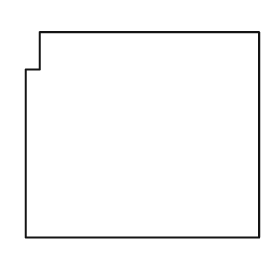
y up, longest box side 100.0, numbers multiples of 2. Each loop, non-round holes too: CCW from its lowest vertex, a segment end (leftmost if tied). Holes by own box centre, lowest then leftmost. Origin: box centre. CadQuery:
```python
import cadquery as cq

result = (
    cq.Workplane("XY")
    .moveTo(-50.0, -44.0)
    .lineTo(50.0, -44.0)
    .lineTo(50.0, 44.0)
    .lineTo(-44.0, 44.0)
    .lineTo(-44.0, 28.0)
    .lineTo(-50.0, 28.0)
    .close()
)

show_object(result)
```